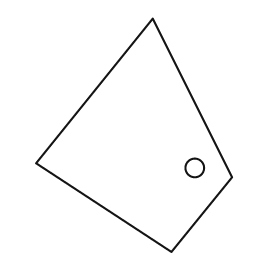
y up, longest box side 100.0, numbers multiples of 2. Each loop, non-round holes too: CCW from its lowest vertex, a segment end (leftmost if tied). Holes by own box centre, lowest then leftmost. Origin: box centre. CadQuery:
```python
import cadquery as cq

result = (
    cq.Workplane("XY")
    .moveTo(16.0, -50.0)
    .lineTo(42.0, -18.0)
    .lineTo(8.0, 50.0)
    .lineTo(-42.0, -12.0)
    .close()
    .moveTo(26.0, -14.0)
    .circle(4.0)
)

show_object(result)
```